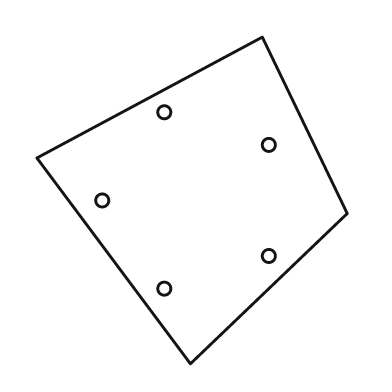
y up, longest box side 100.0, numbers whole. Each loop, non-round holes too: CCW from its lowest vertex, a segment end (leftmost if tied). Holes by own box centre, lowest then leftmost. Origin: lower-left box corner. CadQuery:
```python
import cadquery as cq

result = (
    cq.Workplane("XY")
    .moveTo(47.0, 0.0)
    .lineTo(95.0, 46.0)
    .lineTo(69.0, 100.0)
    .lineTo(0.0, 63.0)
    .close()
    .moveTo(39.0, 23.0)
    .circle(2.0)
    .moveTo(71.0, 33.0)
    .circle(2.0)
    .moveTo(20.0, 50.0)
    .circle(2.0)
    .moveTo(71.0, 67.0)
    .circle(2.0)
    .moveTo(39.0, 77.0)
    .circle(2.0)
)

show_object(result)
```